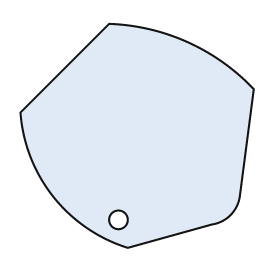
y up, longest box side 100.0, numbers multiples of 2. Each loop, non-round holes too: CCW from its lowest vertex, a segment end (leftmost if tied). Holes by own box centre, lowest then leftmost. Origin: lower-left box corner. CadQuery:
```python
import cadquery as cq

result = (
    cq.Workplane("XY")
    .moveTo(46.0, 0.0)
    .lineTo(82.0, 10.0)
    .threePointArc((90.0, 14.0), (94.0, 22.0))
    .lineTo(100.0, 68.0)
    .threePointArc((72.0, 88.0), (38.0, 96.0))
    .lineTo(0.0, 58.0)
    .threePointArc((14.0, 22.0), (46.0, 0.0))
    .close()
    .moveTo(42.0, 12.0)
    .circle(4.0)
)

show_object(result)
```